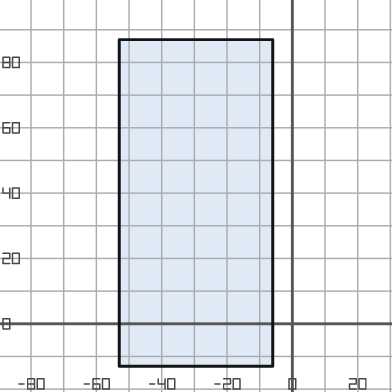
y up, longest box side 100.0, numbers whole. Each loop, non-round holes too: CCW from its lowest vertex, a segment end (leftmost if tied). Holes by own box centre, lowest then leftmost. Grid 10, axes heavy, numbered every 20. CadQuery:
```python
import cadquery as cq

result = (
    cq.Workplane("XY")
    .moveTo(-53.0, -13.0)
    .lineTo(-6.0, -13.0)
    .lineTo(-6.0, 87.0)
    .lineTo(-53.0, 87.0)
    .close()
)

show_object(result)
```